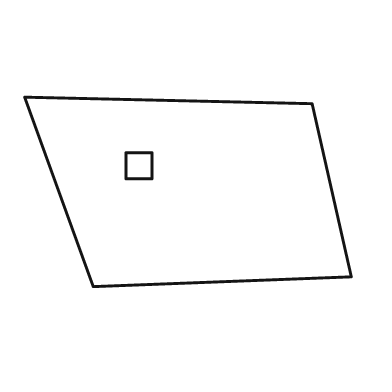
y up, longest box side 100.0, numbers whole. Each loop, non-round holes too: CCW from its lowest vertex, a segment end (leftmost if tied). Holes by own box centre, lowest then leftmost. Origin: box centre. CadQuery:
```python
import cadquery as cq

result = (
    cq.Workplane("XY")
    .moveTo(-29.0, -29.0)
    .lineTo(50.0, -26.0)
    .lineTo(38.0, 27.0)
    .lineTo(-50.0, 29.0)
    .close()
    .moveTo(-19.0, 4.0)
    .lineTo(-11.0, 4.0)
    .lineTo(-11.0, 12.0)
    .lineTo(-19.0, 12.0)
    .close()
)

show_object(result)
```